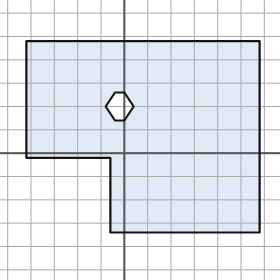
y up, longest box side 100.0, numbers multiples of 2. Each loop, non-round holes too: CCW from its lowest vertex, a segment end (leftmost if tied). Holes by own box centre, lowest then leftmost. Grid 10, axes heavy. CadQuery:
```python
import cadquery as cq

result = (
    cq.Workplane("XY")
    .moveTo(-6.0, -34.0)
    .lineTo(58.0, -34.0)
    .lineTo(58.0, 48.0)
    .lineTo(-42.0, 48.0)
    .lineTo(-42.0, -2.0)
    .lineTo(-6.0, -2.0)
    .close()
    .moveTo(-4.0, 14.0)
    .lineTo(0.0, 14.0)
    .lineTo(4.0, 20.0)
    .lineTo(0.0, 26.0)
    .lineTo(-4.0, 26.0)
    .lineTo(-8.0, 20.0)
    .close()
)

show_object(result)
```